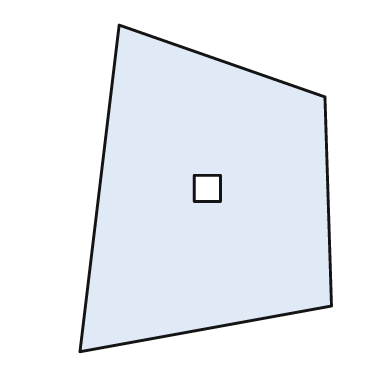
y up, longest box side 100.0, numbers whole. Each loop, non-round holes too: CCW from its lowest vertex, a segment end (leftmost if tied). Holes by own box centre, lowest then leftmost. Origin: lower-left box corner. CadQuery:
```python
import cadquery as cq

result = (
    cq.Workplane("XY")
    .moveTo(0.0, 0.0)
    .lineTo(77.0, 14.0)
    .lineTo(75.0, 78.0)
    .lineTo(12.0, 100.0)
    .close()
    .moveTo(35.0, 46.0)
    .lineTo(43.0, 46.0)
    .lineTo(43.0, 54.0)
    .lineTo(35.0, 54.0)
    .close()
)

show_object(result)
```